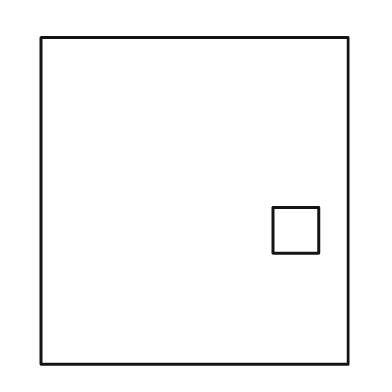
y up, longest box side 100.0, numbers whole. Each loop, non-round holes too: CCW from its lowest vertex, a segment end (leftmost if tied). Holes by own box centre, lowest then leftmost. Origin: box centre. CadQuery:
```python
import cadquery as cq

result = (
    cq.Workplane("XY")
    .moveTo(-47.0, -50.0)
    .lineTo(47.0, -50.0)
    .lineTo(47.0, 50.0)
    .lineTo(-47.0, 50.0)
    .close()
    .moveTo(24.0, -16.0)
    .lineTo(38.0, -16.0)
    .lineTo(38.0, -2.0)
    .lineTo(24.0, -2.0)
    .close()
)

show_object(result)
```